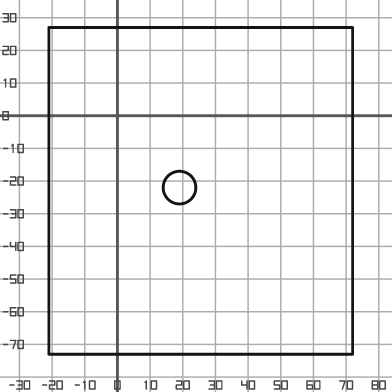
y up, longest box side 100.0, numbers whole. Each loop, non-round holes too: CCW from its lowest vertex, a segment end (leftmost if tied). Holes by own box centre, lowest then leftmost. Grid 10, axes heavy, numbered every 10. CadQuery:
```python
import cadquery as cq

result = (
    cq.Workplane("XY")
    .moveTo(-21.0, -73.0)
    .lineTo(72.0, -73.0)
    .lineTo(72.0, 27.0)
    .lineTo(-21.0, 27.0)
    .close()
    .moveTo(19.0, -22.0)
    .circle(5.0)
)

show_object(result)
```